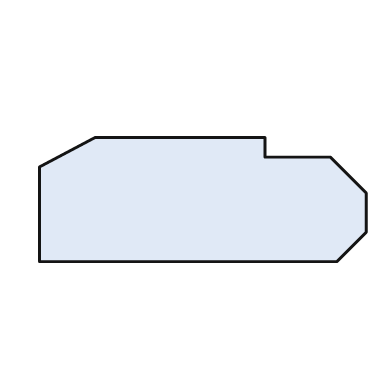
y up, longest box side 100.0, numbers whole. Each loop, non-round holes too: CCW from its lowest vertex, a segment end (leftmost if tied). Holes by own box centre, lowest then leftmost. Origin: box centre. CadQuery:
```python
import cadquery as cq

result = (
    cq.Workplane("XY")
    .moveTo(-50.0, -19.0)
    .lineTo(41.0, -19.0)
    .lineTo(50.0, -10.0)
    .lineTo(50.0, 2.0)
    .lineTo(39.0, 13.0)
    .lineTo(19.0, 13.0)
    .lineTo(19.0, 19.0)
    .lineTo(-33.0, 19.0)
    .lineTo(-50.0, 10.0)
    .close()
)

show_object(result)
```